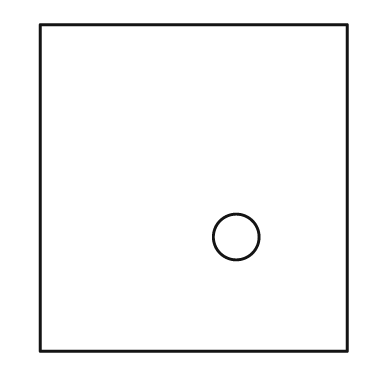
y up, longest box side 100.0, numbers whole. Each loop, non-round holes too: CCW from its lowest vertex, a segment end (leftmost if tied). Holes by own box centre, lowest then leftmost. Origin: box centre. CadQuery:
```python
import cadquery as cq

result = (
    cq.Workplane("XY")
    .moveTo(-47.0, -50.0)
    .lineTo(47.0, -50.0)
    .lineTo(47.0, 50.0)
    .lineTo(-47.0, 50.0)
    .close()
    .moveTo(13.0, -15.0)
    .circle(7.0)
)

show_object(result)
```